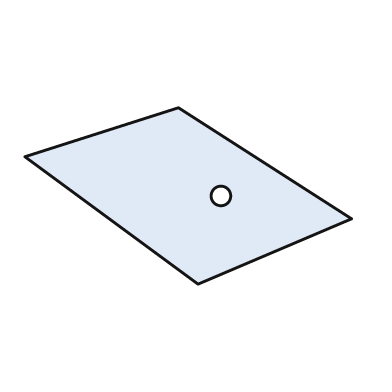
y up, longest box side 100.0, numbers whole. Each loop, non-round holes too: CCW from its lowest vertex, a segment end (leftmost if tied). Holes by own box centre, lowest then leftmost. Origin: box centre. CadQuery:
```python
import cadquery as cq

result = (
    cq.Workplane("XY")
    .moveTo(3.0, -27.0)
    .lineTo(50.0, -7.0)
    .lineTo(-3.0, 27.0)
    .lineTo(-50.0, 12.0)
    .close()
    .moveTo(10.0, 0.0)
    .circle(3.0)
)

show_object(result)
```